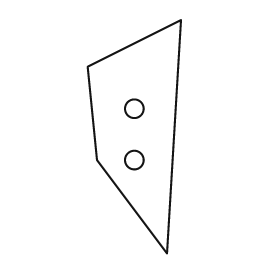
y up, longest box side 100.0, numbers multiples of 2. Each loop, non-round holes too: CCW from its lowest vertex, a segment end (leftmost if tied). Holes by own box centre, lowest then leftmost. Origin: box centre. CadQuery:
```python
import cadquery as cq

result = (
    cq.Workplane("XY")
    .moveTo(14.0, -50.0)
    .lineTo(20.0, 50.0)
    .lineTo(-20.0, 30.0)
    .lineTo(-16.0, -10.0)
    .close()
    .moveTo(0.0, -10.0)
    .circle(4.0)
    .moveTo(0.0, 12.0)
    .circle(4.0)
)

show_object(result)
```